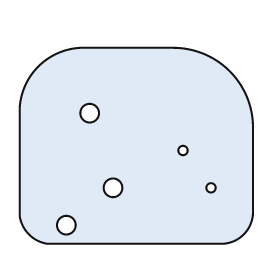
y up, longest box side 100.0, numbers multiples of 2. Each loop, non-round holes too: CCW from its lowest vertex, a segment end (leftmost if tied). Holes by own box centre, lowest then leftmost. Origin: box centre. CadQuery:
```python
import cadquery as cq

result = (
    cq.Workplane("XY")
    .moveTo(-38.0, -42.0)
    .lineTo(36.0, -42.0)
    .threePointArc((46.0, -38.0), (50.0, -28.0))
    .lineTo(50.0, 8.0)
    .threePointArc((40.0, 32.0), (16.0, 42.0))
    .lineTo(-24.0, 42.0)
    .threePointArc((-42.0, 34.0), (-50.0, 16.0))
    .lineTo(-50.0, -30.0)
    .threePointArc((-46.0, -38.0), (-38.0, -42.0))
    .close()
    .moveTo(-30.0, -34.0)
    .circle(4.0)
    .moveTo(-10.0, -18.0)
    .circle(4.0)
    .moveTo(32.0, -18.0)
    .circle(2.0)
    .moveTo(20.0, -2.0)
    .circle(2.0)
    .moveTo(-20.0, 14.0)
    .circle(4.0)
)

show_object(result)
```